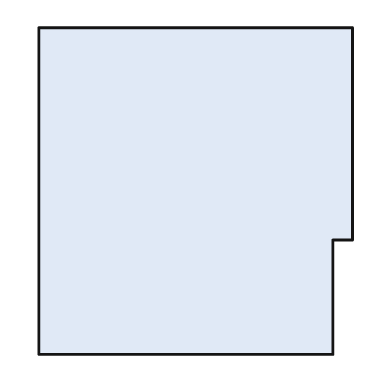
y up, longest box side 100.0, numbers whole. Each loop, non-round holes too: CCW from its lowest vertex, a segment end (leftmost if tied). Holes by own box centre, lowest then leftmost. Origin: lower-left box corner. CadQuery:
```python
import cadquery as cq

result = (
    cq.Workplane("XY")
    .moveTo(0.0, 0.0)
    .lineTo(90.0, 0.0)
    .lineTo(90.0, 35.0)
    .lineTo(96.0, 35.0)
    .lineTo(96.0, 100.0)
    .lineTo(0.0, 100.0)
    .close()
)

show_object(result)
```